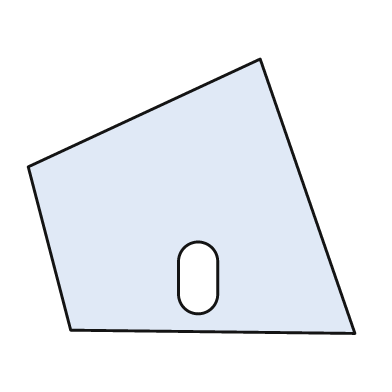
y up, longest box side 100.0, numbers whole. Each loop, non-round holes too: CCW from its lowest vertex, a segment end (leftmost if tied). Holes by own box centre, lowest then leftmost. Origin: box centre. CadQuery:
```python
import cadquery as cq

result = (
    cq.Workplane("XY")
    .moveTo(50.0, -42.0)
    .lineTo(21.0, 42.0)
    .lineTo(-50.0, 9.0)
    .lineTo(-37.0, -41.0)
    .close()
    .moveTo(-4.0, -30.0)
    .threePointArc((2.0, -36.0), (8.0, -30.0))
    .lineTo(8.0, -20.0)
    .threePointArc((2.0, -14.0), (-4.0, -20.0))
    .close()
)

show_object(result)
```